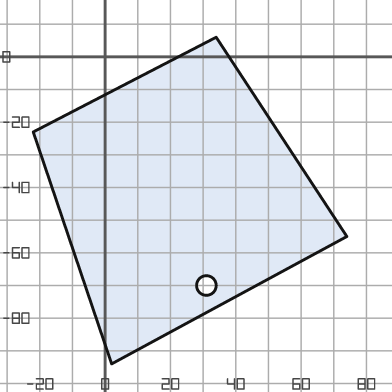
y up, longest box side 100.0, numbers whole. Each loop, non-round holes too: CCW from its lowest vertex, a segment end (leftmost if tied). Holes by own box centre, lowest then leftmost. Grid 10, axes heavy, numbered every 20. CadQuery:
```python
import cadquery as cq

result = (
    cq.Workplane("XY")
    .moveTo(2.0, -94.0)
    .lineTo(74.0, -55.0)
    .lineTo(34.0, 6.0)
    .lineTo(-22.0, -23.0)
    .close()
    .moveTo(31.0, -70.0)
    .circle(3.0)
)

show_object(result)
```